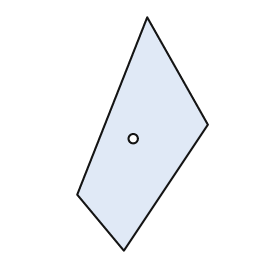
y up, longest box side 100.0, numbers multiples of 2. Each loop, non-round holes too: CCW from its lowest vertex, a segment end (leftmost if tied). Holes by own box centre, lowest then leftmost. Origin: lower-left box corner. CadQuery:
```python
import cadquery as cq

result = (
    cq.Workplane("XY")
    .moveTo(20.0, 0.0)
    .lineTo(56.0, 54.0)
    .lineTo(30.0, 100.0)
    .lineTo(0.0, 24.0)
    .close()
    .moveTo(24.0, 48.0)
    .circle(2.0)
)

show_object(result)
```